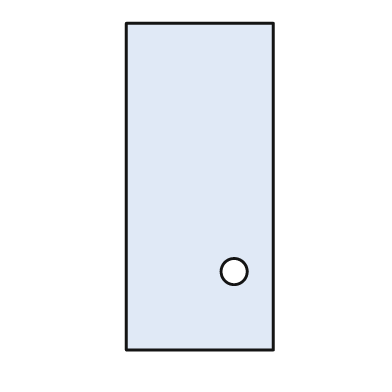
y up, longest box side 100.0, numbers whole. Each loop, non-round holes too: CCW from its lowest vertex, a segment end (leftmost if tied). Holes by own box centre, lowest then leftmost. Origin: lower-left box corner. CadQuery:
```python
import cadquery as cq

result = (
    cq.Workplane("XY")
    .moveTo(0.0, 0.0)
    .lineTo(45.0, 0.0)
    .lineTo(45.0, 100.0)
    .lineTo(0.0, 100.0)
    .close()
    .moveTo(33.0, 24.0)
    .circle(4.0)
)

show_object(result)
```